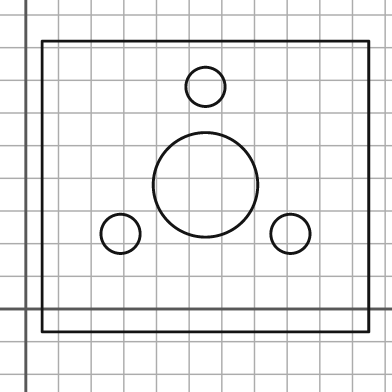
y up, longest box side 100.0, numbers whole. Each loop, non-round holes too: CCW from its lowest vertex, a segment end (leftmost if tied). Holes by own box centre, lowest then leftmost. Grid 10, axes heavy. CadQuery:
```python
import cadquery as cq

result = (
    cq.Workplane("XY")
    .moveTo(5.0, -7.0)
    .lineTo(105.0, -7.0)
    .lineTo(105.0, 82.0)
    .lineTo(5.0, 82.0)
    .close()
    .moveTo(29.0, 23.0)
    .circle(6.0)
    .moveTo(81.0, 23.0)
    .circle(6.0)
    .moveTo(55.0, 38.0)
    .circle(16.0)
    .moveTo(55.0, 68.0)
    .circle(6.0)
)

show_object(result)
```